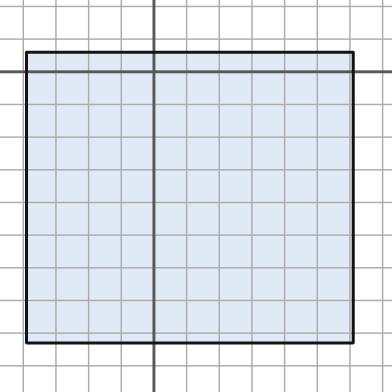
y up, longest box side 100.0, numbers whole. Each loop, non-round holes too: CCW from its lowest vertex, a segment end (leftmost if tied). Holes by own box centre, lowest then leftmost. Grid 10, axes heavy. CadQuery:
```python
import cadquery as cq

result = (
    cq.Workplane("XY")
    .moveTo(-39.0, -83.0)
    .lineTo(61.0, -83.0)
    .lineTo(61.0, 6.0)
    .lineTo(-39.0, 6.0)
    .close()
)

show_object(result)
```